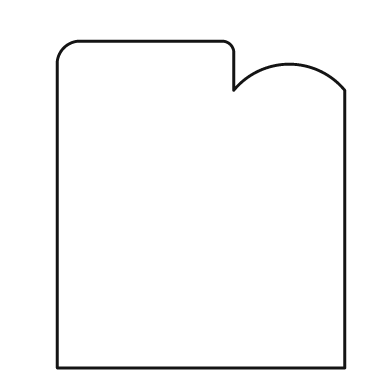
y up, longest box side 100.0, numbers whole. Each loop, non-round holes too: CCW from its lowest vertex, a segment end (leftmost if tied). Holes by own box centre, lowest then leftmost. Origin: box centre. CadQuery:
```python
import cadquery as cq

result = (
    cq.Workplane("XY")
    .moveTo(-44.0, -50.0)
    .lineTo(44.0, -50.0)
    .lineTo(44.0, 35.0)
    .threePointArc((27.0, 43.0), (10.0, 35.0))
    .lineTo(10.0, 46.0)
    .threePointArc((9.0, 49.0), (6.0, 50.0))
    .lineTo(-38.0, 50.0)
    .threePointArc((-42.0, 48.0), (-44.0, 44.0))
    .close()
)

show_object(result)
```